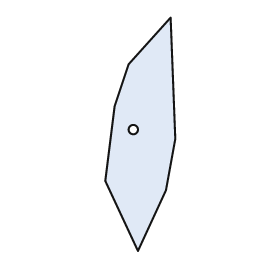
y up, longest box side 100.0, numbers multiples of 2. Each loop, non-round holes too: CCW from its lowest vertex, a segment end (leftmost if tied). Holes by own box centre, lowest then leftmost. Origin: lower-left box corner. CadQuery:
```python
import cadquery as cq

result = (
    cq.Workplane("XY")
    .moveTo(14.0, 0.0)
    .lineTo(26.0, 26.0)
    .lineTo(30.0, 48.0)
    .lineTo(28.0, 100.0)
    .lineTo(10.0, 80.0)
    .lineTo(4.0, 62.0)
    .lineTo(0.0, 30.0)
    .close()
    .moveTo(12.0, 52.0)
    .circle(2.0)
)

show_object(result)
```